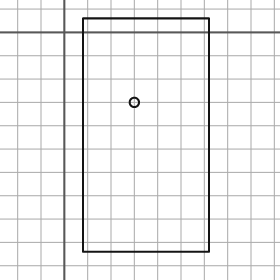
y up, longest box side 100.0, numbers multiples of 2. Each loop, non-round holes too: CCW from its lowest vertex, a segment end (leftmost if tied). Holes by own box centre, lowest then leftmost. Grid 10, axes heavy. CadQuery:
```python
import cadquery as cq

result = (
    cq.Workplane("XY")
    .moveTo(8.0, -94.0)
    .lineTo(62.0, -94.0)
    .lineTo(62.0, 6.0)
    .lineTo(8.0, 6.0)
    .close()
    .moveTo(30.0, -30.0)
    .circle(2.0)
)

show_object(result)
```